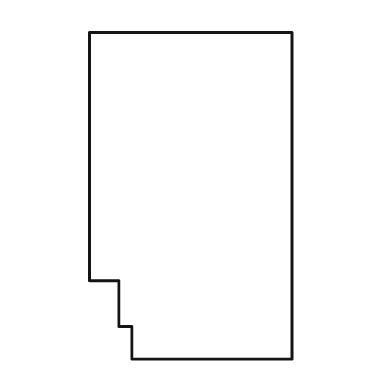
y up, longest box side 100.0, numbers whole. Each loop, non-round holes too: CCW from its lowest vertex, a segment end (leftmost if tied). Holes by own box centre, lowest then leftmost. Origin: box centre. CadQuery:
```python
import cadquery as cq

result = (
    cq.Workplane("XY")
    .moveTo(-18.0, -50.0)
    .lineTo(31.0, -50.0)
    .lineTo(31.0, 50.0)
    .lineTo(-31.0, 50.0)
    .lineTo(-31.0, -26.0)
    .lineTo(-22.0, -26.0)
    .lineTo(-22.0, -40.0)
    .lineTo(-18.0, -40.0)
    .close()
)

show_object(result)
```